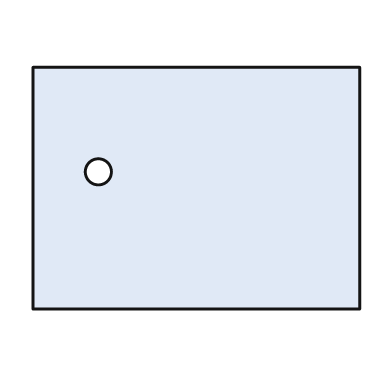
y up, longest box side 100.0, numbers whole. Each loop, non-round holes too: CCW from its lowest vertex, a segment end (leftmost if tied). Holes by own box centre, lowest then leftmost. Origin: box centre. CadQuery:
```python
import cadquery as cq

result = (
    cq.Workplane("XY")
    .moveTo(-50.0, -37.0)
    .lineTo(50.0, -37.0)
    .lineTo(50.0, 37.0)
    .lineTo(-50.0, 37.0)
    .close()
    .moveTo(-30.0, 5.0)
    .circle(4.0)
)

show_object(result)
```